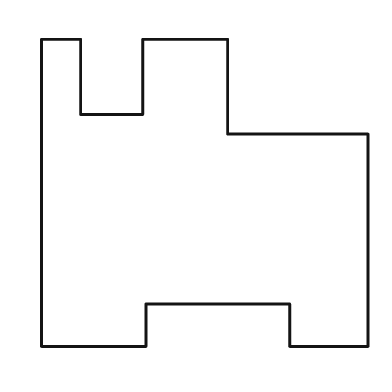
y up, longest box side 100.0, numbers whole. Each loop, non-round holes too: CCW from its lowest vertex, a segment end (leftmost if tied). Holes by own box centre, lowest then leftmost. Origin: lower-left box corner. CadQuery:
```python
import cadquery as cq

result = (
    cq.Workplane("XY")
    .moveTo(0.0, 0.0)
    .lineTo(32.0, 0.0)
    .lineTo(32.0, 13.0)
    .lineTo(76.0, 13.0)
    .lineTo(76.0, 0.0)
    .lineTo(100.0, 0.0)
    .lineTo(100.0, 65.0)
    .lineTo(57.0, 65.0)
    .lineTo(57.0, 94.0)
    .lineTo(31.0, 94.0)
    .lineTo(31.0, 71.0)
    .lineTo(12.0, 71.0)
    .lineTo(12.0, 94.0)
    .lineTo(0.0, 94.0)
    .close()
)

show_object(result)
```